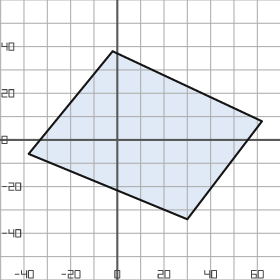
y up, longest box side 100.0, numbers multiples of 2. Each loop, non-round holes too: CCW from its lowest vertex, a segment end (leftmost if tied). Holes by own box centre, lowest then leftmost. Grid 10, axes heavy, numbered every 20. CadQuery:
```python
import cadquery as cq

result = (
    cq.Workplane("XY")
    .moveTo(30.0, -34.0)
    .lineTo(62.0, 8.0)
    .lineTo(-2.0, 38.0)
    .lineTo(-38.0, -6.0)
    .close()
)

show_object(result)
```